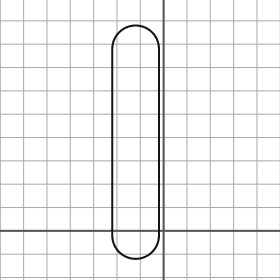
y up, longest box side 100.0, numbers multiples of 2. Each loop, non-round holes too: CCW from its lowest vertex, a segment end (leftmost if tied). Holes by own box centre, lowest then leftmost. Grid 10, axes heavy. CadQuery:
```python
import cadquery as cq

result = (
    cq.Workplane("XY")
    .moveTo(-22.0, -2.0)
    .threePointArc((-12.0, -12.0), (-2.0, -2.0))
    .lineTo(-2.0, 78.0)
    .threePointArc((-12.0, 88.0), (-22.0, 78.0))
    .close()
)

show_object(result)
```